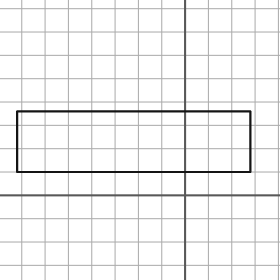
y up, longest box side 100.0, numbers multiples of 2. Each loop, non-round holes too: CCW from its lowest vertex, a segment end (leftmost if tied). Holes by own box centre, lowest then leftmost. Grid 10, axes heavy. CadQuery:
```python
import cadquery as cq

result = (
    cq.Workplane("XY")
    .moveTo(-72.0, 10.0)
    .lineTo(28.0, 10.0)
    .lineTo(28.0, 36.0)
    .lineTo(-72.0, 36.0)
    .close()
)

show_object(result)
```